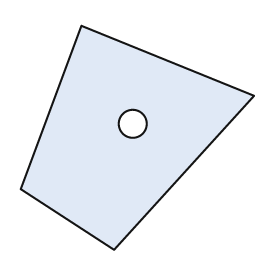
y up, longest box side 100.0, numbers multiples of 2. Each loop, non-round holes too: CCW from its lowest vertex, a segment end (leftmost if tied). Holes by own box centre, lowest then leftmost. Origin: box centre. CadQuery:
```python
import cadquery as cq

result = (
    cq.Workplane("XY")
    .moveTo(-10.0, -48.0)
    .lineTo(50.0, 18.0)
    .lineTo(-24.0, 48.0)
    .lineTo(-50.0, -22.0)
    .close()
    .moveTo(-2.0, 6.0)
    .circle(6.0)
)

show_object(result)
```